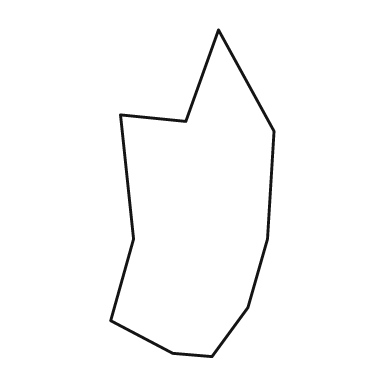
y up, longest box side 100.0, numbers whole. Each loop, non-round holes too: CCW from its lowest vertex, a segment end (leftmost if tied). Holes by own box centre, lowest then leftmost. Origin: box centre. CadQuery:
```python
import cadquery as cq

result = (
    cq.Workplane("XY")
    .moveTo(6.0, -50.0)
    .lineTo(17.0, -35.0)
    .lineTo(23.0, -14.0)
    .lineTo(25.0, 19.0)
    .lineTo(8.0, 50.0)
    .lineTo(-2.0, 22.0)
    .lineTo(-22.0, 24.0)
    .lineTo(-18.0, -14.0)
    .lineTo(-25.0, -39.0)
    .lineTo(-6.0, -49.0)
    .close()
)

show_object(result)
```